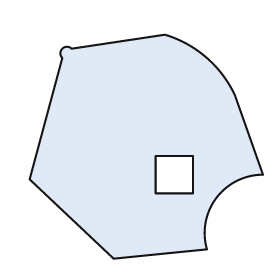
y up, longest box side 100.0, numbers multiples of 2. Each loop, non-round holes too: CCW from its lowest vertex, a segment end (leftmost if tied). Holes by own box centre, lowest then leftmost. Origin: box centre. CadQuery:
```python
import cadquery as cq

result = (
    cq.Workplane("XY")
    .moveTo(-14.0, -48.0)
    .lineTo(26.0, -44.0)
    .threePointArc((30.0, -22.0), (50.0, -12.0))
    .lineTo(38.0, 22.0)
    .threePointArc((26.0, 38.0), (8.0, 48.0))
    .lineTo(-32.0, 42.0)
    .threePointArc((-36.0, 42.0), (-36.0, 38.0))
    .lineTo(-50.0, -14.0)
    .close()
    .moveTo(4.0, -20.0)
    .lineTo(20.0, -20.0)
    .lineTo(20.0, -4.0)
    .lineTo(4.0, -4.0)
    .close()
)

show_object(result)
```